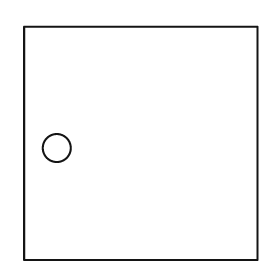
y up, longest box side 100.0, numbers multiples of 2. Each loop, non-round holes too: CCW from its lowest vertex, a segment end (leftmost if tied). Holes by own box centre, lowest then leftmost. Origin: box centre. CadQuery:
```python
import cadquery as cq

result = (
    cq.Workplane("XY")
    .moveTo(-50.0, -50.0)
    .lineTo(50.0, -50.0)
    .lineTo(50.0, 50.0)
    .lineTo(-50.0, 50.0)
    .close()
    .moveTo(-36.0, -2.0)
    .circle(6.0)
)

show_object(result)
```